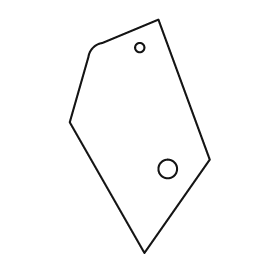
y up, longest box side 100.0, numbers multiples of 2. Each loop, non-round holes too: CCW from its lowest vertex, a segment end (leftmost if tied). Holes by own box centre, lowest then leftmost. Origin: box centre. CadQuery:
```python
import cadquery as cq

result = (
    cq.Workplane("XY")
    .moveTo(2.0, -50.0)
    .lineTo(30.0, -10.0)
    .lineTo(8.0, 50.0)
    .lineTo(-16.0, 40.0)
    .threePointArc((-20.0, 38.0), (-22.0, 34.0))
    .lineTo(-30.0, 6.0)
    .close()
    .moveTo(12.0, -14.0)
    .circle(4.0)
    .moveTo(0.0, 38.0)
    .circle(2.0)
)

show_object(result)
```